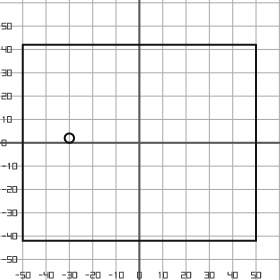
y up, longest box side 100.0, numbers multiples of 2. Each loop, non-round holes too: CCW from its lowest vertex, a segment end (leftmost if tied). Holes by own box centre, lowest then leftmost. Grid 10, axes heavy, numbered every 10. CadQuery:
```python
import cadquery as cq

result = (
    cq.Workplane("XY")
    .moveTo(-50.0, -42.0)
    .lineTo(50.0, -42.0)
    .lineTo(50.0, 42.0)
    .lineTo(-50.0, 42.0)
    .close()
    .moveTo(-30.0, 2.0)
    .circle(2.0)
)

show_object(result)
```